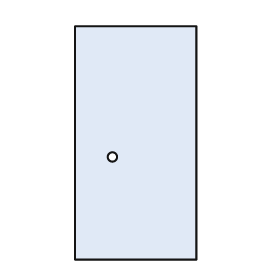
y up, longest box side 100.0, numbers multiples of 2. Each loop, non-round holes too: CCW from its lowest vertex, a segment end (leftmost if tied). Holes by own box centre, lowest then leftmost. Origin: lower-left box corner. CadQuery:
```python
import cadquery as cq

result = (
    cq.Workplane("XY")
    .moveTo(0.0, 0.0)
    .lineTo(52.0, 0.0)
    .lineTo(52.0, 100.0)
    .lineTo(0.0, 100.0)
    .close()
    .moveTo(16.0, 44.0)
    .circle(2.0)
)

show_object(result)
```